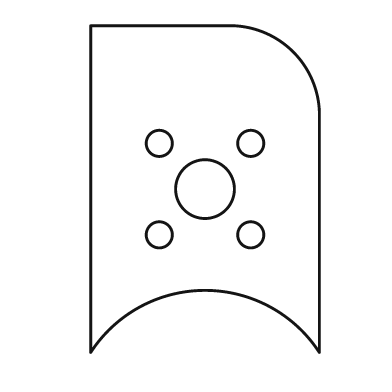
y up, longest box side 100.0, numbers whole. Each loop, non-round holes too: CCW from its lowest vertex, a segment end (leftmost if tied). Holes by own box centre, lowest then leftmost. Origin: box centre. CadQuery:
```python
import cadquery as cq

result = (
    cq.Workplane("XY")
    .moveTo(-35.0, -50.0)
    .threePointArc((0.0, -31.0), (35.0, -50.0))
    .lineTo(35.0, 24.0)
    .threePointArc((27.0, 42.0), (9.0, 50.0))
    .lineTo(-35.0, 50.0)
    .close()
    .moveTo(-14.0, -14.0)
    .circle(4.0)
    .moveTo(14.0, -14.0)
    .circle(4.0)
    .moveTo(0.0, 0.0)
    .circle(9.0)
    .moveTo(-14.0, 14.0)
    .circle(4.0)
    .moveTo(14.0, 14.0)
    .circle(4.0)
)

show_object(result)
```